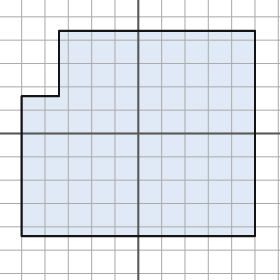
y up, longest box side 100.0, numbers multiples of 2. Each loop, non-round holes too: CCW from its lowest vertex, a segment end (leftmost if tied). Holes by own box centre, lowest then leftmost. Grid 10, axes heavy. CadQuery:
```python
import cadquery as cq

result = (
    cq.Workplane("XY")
    .moveTo(-50.0, -44.0)
    .lineTo(50.0, -44.0)
    .lineTo(50.0, 44.0)
    .lineTo(-34.0, 44.0)
    .lineTo(-34.0, 16.0)
    .lineTo(-50.0, 16.0)
    .close()
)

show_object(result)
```